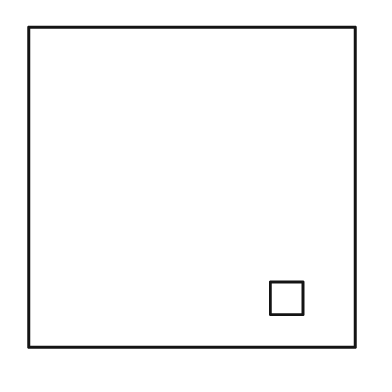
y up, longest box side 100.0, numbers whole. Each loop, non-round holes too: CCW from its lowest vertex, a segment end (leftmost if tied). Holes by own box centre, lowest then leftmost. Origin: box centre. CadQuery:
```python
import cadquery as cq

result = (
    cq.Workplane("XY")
    .moveTo(-50.0, -49.0)
    .lineTo(50.0, -49.0)
    .lineTo(50.0, 49.0)
    .lineTo(-50.0, 49.0)
    .close()
    .moveTo(24.0, -39.0)
    .lineTo(34.0, -39.0)
    .lineTo(34.0, -29.0)
    .lineTo(24.0, -29.0)
    .close()
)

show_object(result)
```